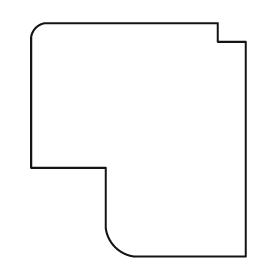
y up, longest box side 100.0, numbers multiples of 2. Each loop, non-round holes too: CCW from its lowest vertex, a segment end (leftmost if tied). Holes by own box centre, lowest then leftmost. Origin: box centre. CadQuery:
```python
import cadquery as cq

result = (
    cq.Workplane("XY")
    .moveTo(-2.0, -50.0)
    .lineTo(46.0, -50.0)
    .lineTo(46.0, 42.0)
    .lineTo(34.0, 42.0)
    .lineTo(34.0, 50.0)
    .lineTo(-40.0, 50.0)
    .threePointArc((-44.0, 48.0), (-46.0, 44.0))
    .lineTo(-46.0, -12.0)
    .lineTo(-14.0, -12.0)
    .lineTo(-14.0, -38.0)
    .threePointArc((-10.0, -46.0), (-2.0, -50.0))
    .close()
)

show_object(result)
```